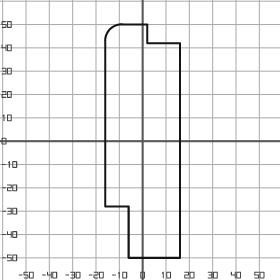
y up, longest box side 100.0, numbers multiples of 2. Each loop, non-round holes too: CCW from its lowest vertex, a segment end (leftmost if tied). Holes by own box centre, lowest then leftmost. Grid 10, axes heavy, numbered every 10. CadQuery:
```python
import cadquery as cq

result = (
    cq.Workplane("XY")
    .moveTo(-6.0, -50.0)
    .lineTo(16.0, -50.0)
    .lineTo(16.0, 42.0)
    .lineTo(2.0, 42.0)
    .lineTo(2.0, 50.0)
    .lineTo(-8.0, 50.0)
    .threePointArc((-14.0, 48.0), (-16.0, 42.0))
    .lineTo(-16.0, -28.0)
    .lineTo(-6.0, -28.0)
    .close()
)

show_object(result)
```